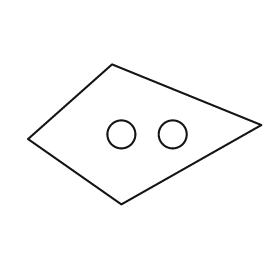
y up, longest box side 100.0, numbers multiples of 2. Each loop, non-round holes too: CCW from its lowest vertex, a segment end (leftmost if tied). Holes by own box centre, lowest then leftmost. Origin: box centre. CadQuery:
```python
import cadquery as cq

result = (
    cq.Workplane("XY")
    .moveTo(-10.0, -30.0)
    .lineTo(50.0, 4.0)
    .lineTo(-14.0, 30.0)
    .lineTo(-50.0, -2.0)
    .close()
    .moveTo(-10.0, 0.0)
    .circle(6.0)
    .moveTo(12.0, 0.0)
    .circle(6.0)
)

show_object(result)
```